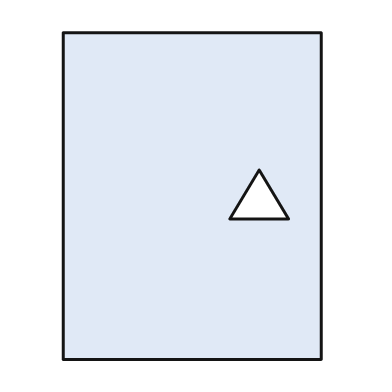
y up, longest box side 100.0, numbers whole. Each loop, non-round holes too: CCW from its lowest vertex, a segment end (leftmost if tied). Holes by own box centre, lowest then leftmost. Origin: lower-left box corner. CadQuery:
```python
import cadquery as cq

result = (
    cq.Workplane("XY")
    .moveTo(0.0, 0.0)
    .lineTo(79.0, 0.0)
    .lineTo(79.0, 100.0)
    .lineTo(0.0, 100.0)
    .close()
    .moveTo(51.0, 43.0)
    .lineTo(69.0, 43.0)
    .lineTo(60.0, 58.0)
    .close()
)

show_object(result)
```